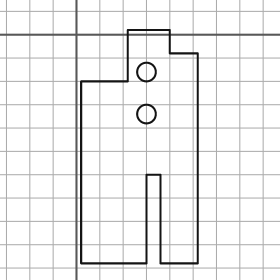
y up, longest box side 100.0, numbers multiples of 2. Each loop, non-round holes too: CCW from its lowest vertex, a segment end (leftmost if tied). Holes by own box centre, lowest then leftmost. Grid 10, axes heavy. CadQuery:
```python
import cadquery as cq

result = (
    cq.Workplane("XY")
    .moveTo(2.0, -98.0)
    .lineTo(30.0, -98.0)
    .lineTo(30.0, -60.0)
    .lineTo(36.0, -60.0)
    .lineTo(36.0, -98.0)
    .lineTo(52.0, -98.0)
    .lineTo(52.0, -8.0)
    .lineTo(40.0, -8.0)
    .lineTo(40.0, 2.0)
    .lineTo(22.0, 2.0)
    .lineTo(22.0, -20.0)
    .lineTo(2.0, -20.0)
    .close()
    .moveTo(30.0, -34.0)
    .circle(4.0)
    .moveTo(30.0, -16.0)
    .circle(4.0)
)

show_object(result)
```